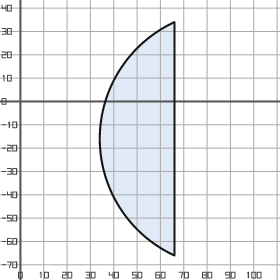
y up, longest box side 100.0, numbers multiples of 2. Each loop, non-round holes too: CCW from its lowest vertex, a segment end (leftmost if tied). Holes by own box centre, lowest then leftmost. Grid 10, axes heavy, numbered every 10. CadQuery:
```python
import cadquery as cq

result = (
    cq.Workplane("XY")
    .moveTo(66.0, -66.0)
    .lineTo(66.0, 34.0)
    .threePointArc((34.0, -16.0), (66.0, -66.0))
    .close()
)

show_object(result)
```